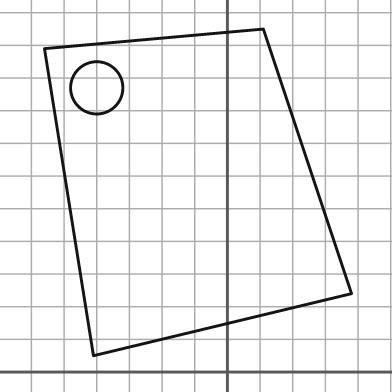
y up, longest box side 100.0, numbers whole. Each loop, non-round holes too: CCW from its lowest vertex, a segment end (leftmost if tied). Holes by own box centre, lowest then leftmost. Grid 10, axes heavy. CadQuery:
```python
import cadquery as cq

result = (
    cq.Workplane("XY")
    .moveTo(-41.0, 5.0)
    .lineTo(38.0, 24.0)
    .lineTo(11.0, 105.0)
    .lineTo(-56.0, 99.0)
    .close()
    .moveTo(-40.0, 87.0)
    .circle(8.0)
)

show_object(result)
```